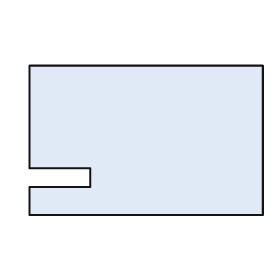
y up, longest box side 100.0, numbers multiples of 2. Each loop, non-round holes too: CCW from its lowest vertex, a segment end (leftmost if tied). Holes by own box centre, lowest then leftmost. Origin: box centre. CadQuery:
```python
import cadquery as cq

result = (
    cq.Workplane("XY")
    .moveTo(-50.0, -32.0)
    .lineTo(50.0, -32.0)
    .lineTo(50.0, 32.0)
    .lineTo(-50.0, 32.0)
    .lineTo(-50.0, -12.0)
    .lineTo(-24.0, -12.0)
    .lineTo(-24.0, -20.0)
    .lineTo(-50.0, -20.0)
    .close()
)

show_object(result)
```